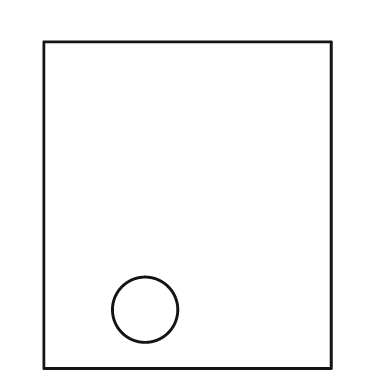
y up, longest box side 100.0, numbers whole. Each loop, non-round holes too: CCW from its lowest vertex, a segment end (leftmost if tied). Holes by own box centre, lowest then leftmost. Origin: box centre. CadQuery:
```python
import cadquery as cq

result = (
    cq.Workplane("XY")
    .moveTo(-44.0, -50.0)
    .lineTo(44.0, -50.0)
    .lineTo(44.0, 50.0)
    .lineTo(-44.0, 50.0)
    .close()
    .moveTo(-13.0, -32.0)
    .circle(10.0)
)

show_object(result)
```